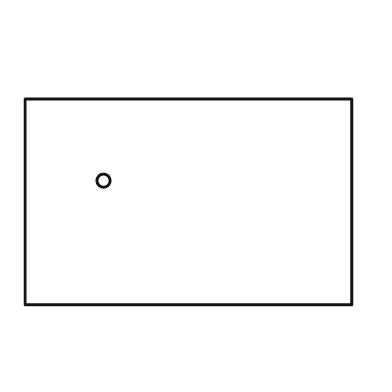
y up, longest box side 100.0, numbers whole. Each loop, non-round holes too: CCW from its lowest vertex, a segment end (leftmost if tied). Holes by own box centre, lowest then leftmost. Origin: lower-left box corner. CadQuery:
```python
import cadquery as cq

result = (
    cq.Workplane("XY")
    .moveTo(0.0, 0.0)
    .lineTo(100.0, 0.0)
    .lineTo(100.0, 63.0)
    .lineTo(0.0, 63.0)
    .close()
    .moveTo(24.0, 38.0)
    .circle(2.0)
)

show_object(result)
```